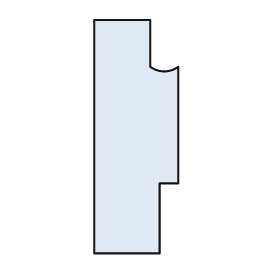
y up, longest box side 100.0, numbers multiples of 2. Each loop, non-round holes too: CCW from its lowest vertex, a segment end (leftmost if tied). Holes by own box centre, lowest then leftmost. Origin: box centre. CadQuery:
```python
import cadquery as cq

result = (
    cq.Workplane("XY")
    .moveTo(-18.0, -50.0)
    .lineTo(10.0, -50.0)
    .lineTo(10.0, -20.0)
    .lineTo(18.0, -20.0)
    .lineTo(18.0, 30.0)
    .threePointArc((12.0, 28.0), (6.0, 30.0))
    .lineTo(6.0, 50.0)
    .lineTo(-18.0, 50.0)
    .close()
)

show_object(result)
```